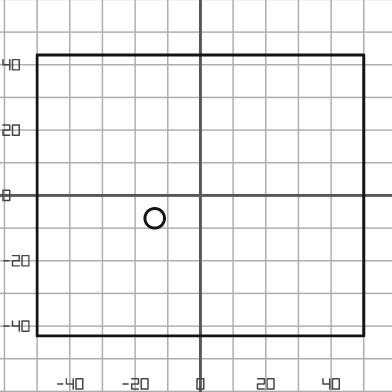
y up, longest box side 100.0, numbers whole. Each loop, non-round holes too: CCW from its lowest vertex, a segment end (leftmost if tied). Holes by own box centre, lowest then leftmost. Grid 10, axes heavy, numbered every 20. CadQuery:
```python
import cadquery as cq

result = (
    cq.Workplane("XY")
    .moveTo(-50.0, -43.0)
    .lineTo(50.0, -43.0)
    .lineTo(50.0, 43.0)
    .lineTo(-50.0, 43.0)
    .close()
    .moveTo(-14.0, -7.0)
    .circle(3.0)
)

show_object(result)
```